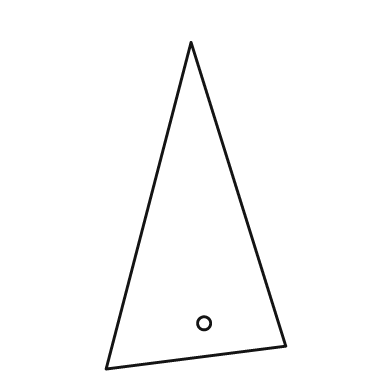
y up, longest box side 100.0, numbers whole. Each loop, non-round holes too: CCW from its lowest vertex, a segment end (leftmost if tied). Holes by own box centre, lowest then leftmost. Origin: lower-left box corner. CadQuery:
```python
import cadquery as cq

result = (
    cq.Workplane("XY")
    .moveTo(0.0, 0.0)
    .lineTo(55.0, 7.0)
    .lineTo(26.0, 100.0)
    .close()
    .moveTo(30.0, 14.0)
    .circle(2.0)
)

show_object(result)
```